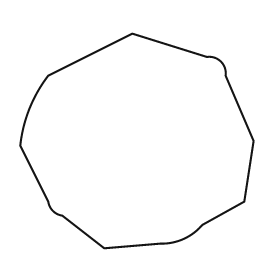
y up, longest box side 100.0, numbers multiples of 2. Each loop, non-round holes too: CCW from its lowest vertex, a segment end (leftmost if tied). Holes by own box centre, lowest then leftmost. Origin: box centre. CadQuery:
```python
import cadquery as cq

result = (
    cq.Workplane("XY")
    .moveTo(-14.0, -46.0)
    .lineTo(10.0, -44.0)
    .threePointArc((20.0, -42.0), (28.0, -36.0))
    .lineTo(46.0, -26.0)
    .lineTo(50.0, 0.0)
    .lineTo(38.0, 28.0)
    .threePointArc((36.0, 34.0), (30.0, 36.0))
    .lineTo(-2.0, 46.0)
    .lineTo(-38.0, 28.0)
    .threePointArc((-46.0, 14.0), (-50.0, -2.0))
    .lineTo(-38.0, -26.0)
    .threePointArc((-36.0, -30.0), (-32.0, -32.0))
    .close()
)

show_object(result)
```